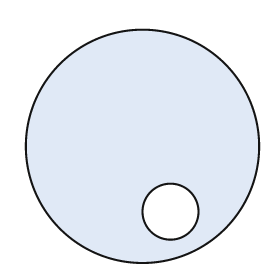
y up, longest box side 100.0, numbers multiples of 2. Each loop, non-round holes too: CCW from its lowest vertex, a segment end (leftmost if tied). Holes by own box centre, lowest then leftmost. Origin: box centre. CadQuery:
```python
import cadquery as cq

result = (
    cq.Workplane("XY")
    .moveTo(0.0, 0.0)
    .circle(50.0)
    .moveTo(12.0, -28.0)
    .circle(12.0)
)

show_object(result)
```